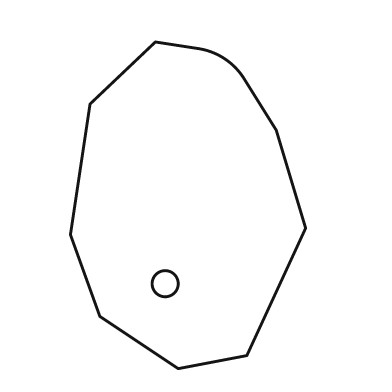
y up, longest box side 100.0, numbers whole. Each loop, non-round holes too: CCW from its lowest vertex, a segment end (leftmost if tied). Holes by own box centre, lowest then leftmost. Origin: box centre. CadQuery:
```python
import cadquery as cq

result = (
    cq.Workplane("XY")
    .moveTo(-3.0, -50.0)
    .lineTo(18.0, -46.0)
    .lineTo(36.0, -7.0)
    .lineTo(27.0, 23.0)
    .lineTo(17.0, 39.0)
    .threePointArc((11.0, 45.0), (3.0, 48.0))
    .lineTo(-10.0, 50.0)
    .lineTo(-30.0, 31.0)
    .lineTo(-36.0, -9.0)
    .lineTo(-27.0, -34.0)
    .close()
    .moveTo(-7.0, -24.0)
    .circle(4.0)
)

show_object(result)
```